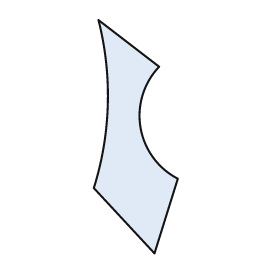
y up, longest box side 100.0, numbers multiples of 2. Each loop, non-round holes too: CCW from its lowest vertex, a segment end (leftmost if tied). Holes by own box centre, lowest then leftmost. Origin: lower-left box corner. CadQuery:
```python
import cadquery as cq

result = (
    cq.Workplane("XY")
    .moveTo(26.0, 0.0)
    .lineTo(36.0, 32.0)
    .threePointArc((20.0, 54.0), (28.0, 80.0))
    .lineTo(2.0, 100.0)
    .threePointArc((6.0, 64.0), (0.0, 28.0))
    .close()
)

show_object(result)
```